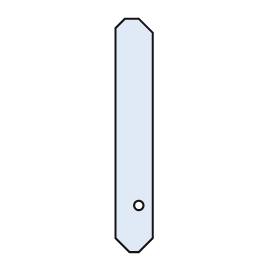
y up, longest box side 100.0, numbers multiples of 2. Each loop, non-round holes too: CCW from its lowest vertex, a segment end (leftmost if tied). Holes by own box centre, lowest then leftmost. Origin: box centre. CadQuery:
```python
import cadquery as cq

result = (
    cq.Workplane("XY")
    .moveTo(-2.0, -50.0)
    .lineTo(2.0, -50.0)
    .lineTo(8.0, -44.0)
    .lineTo(8.0, 44.0)
    .lineTo(2.0, 50.0)
    .lineTo(-4.0, 50.0)
    .lineTo(-8.0, 46.0)
    .lineTo(-8.0, -44.0)
    .close()
    .moveTo(2.0, -30.0)
    .circle(2.0)
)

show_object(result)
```